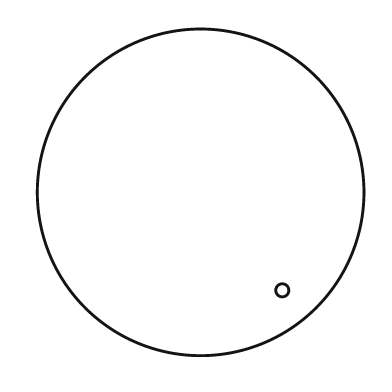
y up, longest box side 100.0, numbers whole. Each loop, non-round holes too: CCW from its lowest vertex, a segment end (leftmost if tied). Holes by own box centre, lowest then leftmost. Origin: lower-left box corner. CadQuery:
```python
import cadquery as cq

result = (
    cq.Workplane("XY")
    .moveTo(50.0, 50.0)
    .circle(50.0)
    .moveTo(75.0, 20.0)
    .circle(2.0)
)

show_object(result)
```